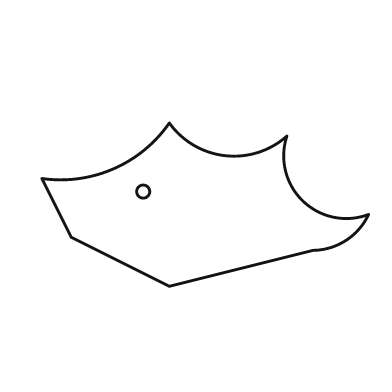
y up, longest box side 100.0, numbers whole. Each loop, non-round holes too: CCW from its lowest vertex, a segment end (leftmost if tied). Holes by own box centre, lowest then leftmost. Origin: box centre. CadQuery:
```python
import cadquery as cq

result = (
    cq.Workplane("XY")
    .moveTo(-11.0, -25.0)
    .lineTo(33.0, -14.0)
    .threePointArc((43.0, -11.0), (50.0, -3.0))
    .threePointArc((30.0, 1.0), (25.0, 21.0))
    .threePointArc((6.0, 15.0), (-11.0, 25.0))
    .threePointArc((-28.0, 11.0), (-50.0, 8.0))
    .lineTo(-41.0, -10.0)
    .close()
    .moveTo(-19.0, 4.0)
    .circle(2.0)
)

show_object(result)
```